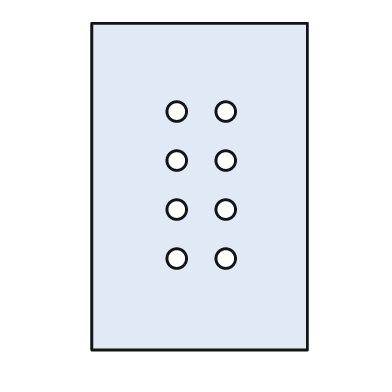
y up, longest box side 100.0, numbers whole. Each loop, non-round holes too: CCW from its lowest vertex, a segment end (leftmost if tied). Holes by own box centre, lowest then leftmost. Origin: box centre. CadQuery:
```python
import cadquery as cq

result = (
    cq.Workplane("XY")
    .moveTo(-33.0, -50.0)
    .lineTo(33.0, -50.0)
    .lineTo(33.0, 50.0)
    .lineTo(-33.0, 50.0)
    .close()
    .moveTo(-7.0, -22.0)
    .circle(3.0)
    .moveTo(8.0, -22.0)
    .circle(3.0)
    .moveTo(-7.0, -7.0)
    .circle(3.0)
    .moveTo(8.0, -7.0)
    .circle(3.0)
    .moveTo(-7.0, 8.0)
    .circle(3.0)
    .moveTo(8.0, 8.0)
    .circle(3.0)
    .moveTo(-7.0, 23.0)
    .circle(3.0)
    .moveTo(8.0, 23.0)
    .circle(3.0)
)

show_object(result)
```